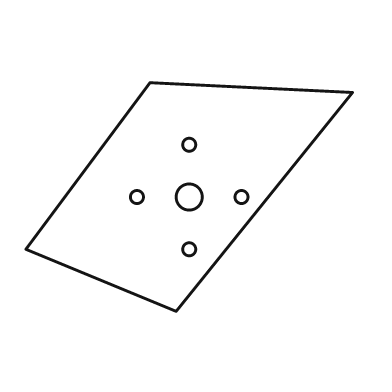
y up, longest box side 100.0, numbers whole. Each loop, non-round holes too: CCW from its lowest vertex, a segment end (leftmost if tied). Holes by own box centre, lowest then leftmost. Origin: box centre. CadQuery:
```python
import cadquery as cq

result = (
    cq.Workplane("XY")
    .moveTo(-4.0, -35.0)
    .lineTo(50.0, 32.0)
    .lineTo(-12.0, 35.0)
    .lineTo(-50.0, -16.0)
    .close()
    .moveTo(0.0, -16.0)
    .circle(2.0)
    .moveTo(-16.0, 0.0)
    .circle(2.0)
    .moveTo(0.0, 0.0)
    .circle(4.0)
    .moveTo(16.0, 0.0)
    .circle(2.0)
    .moveTo(0.0, 16.0)
    .circle(2.0)
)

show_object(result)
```